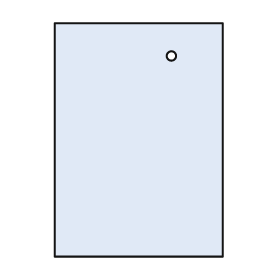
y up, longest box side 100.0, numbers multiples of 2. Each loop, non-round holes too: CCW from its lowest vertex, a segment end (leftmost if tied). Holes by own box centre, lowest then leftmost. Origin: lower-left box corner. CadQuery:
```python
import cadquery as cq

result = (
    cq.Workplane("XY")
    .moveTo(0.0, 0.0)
    .lineTo(72.0, 0.0)
    .lineTo(72.0, 100.0)
    .lineTo(0.0, 100.0)
    .close()
    .moveTo(50.0, 86.0)
    .circle(2.0)
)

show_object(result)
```